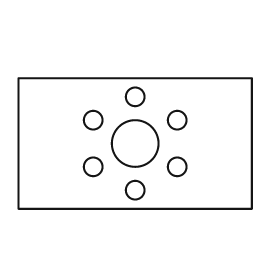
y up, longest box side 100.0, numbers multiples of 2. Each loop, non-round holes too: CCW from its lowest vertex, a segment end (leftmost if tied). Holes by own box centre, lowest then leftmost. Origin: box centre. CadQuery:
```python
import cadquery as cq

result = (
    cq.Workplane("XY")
    .moveTo(-50.0, -28.0)
    .lineTo(50.0, -28.0)
    .lineTo(50.0, 28.0)
    .lineTo(-50.0, 28.0)
    .close()
    .moveTo(0.0, -20.0)
    .circle(4.0)
    .moveTo(-18.0, -10.0)
    .circle(4.0)
    .moveTo(18.0, -10.0)
    .circle(4.0)
    .moveTo(0.0, 0.0)
    .circle(10.0)
    .moveTo(-18.0, 10.0)
    .circle(4.0)
    .moveTo(18.0, 10.0)
    .circle(4.0)
    .moveTo(0.0, 20.0)
    .circle(4.0)
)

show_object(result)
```